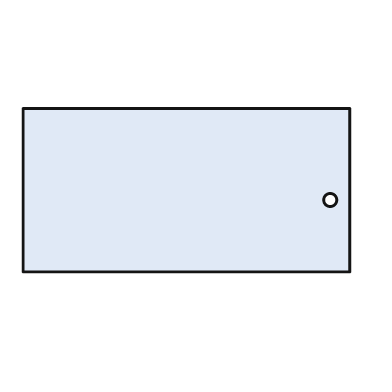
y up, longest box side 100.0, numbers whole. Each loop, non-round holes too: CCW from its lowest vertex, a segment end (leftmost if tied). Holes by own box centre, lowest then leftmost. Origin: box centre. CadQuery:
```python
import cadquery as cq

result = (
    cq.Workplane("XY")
    .moveTo(-50.0, -25.0)
    .lineTo(50.0, -25.0)
    .lineTo(50.0, 25.0)
    .lineTo(-50.0, 25.0)
    .close()
    .moveTo(44.0, -3.0)
    .circle(2.0)
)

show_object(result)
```